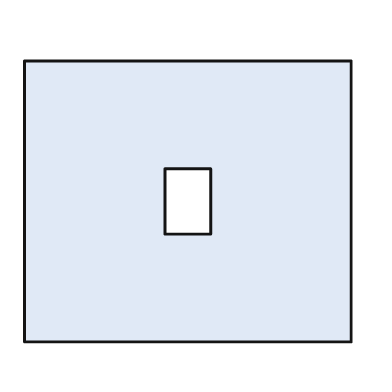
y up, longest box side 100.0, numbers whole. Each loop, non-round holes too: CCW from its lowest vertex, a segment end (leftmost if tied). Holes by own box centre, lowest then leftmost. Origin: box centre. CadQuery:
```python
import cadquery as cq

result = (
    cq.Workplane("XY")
    .moveTo(-50.0, -43.0)
    .lineTo(50.0, -43.0)
    .lineTo(50.0, 43.0)
    .lineTo(-50.0, 43.0)
    .close()
    .moveTo(-7.0, -10.0)
    .lineTo(7.0, -10.0)
    .lineTo(7.0, 10.0)
    .lineTo(-7.0, 10.0)
    .close()
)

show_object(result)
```